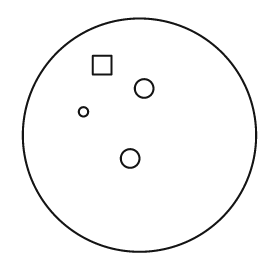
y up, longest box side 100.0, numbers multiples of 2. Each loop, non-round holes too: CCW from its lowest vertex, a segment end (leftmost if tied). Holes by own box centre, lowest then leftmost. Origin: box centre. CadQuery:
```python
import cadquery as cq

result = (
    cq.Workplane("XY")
    .moveTo(0.0, 0.0)
    .circle(50.0)
    .moveTo(-4.0, -10.0)
    .circle(4.0)
    .moveTo(-24.0, 10.0)
    .circle(2.0)
    .moveTo(2.0, 20.0)
    .circle(4.0)
    .moveTo(-20.0, 26.0)
    .lineTo(-12.0, 26.0)
    .lineTo(-12.0, 34.0)
    .lineTo(-20.0, 34.0)
    .close()
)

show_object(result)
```